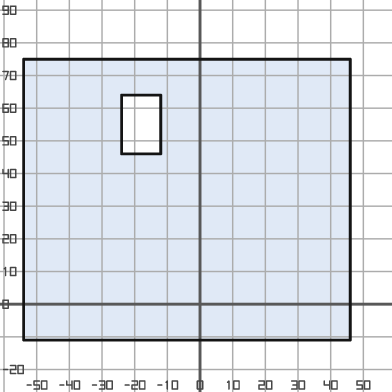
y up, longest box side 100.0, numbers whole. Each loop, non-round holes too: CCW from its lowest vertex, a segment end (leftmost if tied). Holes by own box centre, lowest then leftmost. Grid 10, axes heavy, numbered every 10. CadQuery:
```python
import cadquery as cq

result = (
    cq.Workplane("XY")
    .moveTo(-54.0, -11.0)
    .lineTo(46.0, -11.0)
    .lineTo(46.0, 75.0)
    .lineTo(-54.0, 75.0)
    .close()
    .moveTo(-24.0, 46.0)
    .lineTo(-12.0, 46.0)
    .lineTo(-12.0, 64.0)
    .lineTo(-24.0, 64.0)
    .close()
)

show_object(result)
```